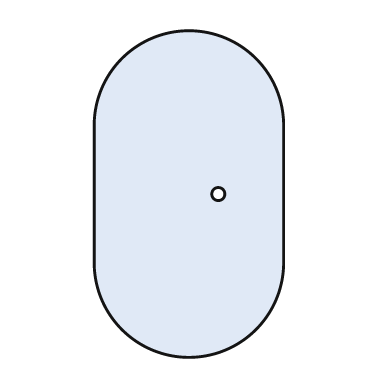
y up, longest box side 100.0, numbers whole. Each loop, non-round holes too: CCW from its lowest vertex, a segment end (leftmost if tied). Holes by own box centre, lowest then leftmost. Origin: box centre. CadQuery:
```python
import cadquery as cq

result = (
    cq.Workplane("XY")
    .moveTo(-29.0, -21.0)
    .threePointArc((0.0, -50.0), (29.0, -21.0))
    .lineTo(29.0, 21.0)
    .threePointArc((0.0, 50.0), (-29.0, 21.0))
    .close()
    .moveTo(9.0, 0.0)
    .circle(2.0)
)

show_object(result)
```